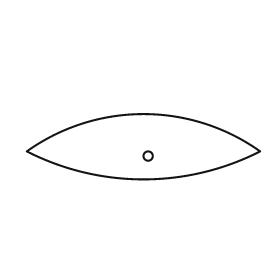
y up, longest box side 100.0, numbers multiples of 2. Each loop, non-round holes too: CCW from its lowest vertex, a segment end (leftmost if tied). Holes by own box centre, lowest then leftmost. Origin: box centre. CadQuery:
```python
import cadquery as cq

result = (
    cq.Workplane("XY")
    .moveTo(-50.0, -2.0)
    .threePointArc((0.0, -14.0), (50.0, -2.0))
    .threePointArc((0.0, 14.0), (-50.0, -2.0))
    .close()
    .moveTo(2.0, -4.0)
    .circle(2.0)
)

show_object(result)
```